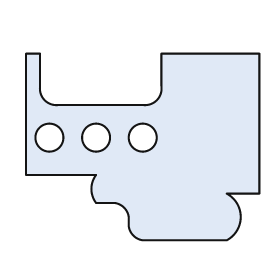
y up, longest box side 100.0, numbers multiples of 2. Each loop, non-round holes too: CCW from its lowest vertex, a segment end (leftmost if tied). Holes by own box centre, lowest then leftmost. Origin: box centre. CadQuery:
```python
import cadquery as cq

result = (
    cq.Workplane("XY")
    .moveTo(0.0, -40.0)
    .lineTo(36.0, -40.0)
    .threePointArc((42.0, -30.0), (36.0, -20.0))
    .lineTo(50.0, -20.0)
    .lineTo(50.0, 40.0)
    .lineTo(8.0, 40.0)
    .lineTo(8.0, 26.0)
    .threePointArc((6.0, 20.0), (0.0, 18.0))
    .lineTo(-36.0, 18.0)
    .threePointArc((-42.0, 20.0), (-44.0, 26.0))
    .lineTo(-44.0, 40.0)
    .lineTo(-50.0, 40.0)
    .lineTo(-50.0, -12.0)
    .lineTo(-20.0, -12.0)
    .threePointArc((-22.0, -18.0), (-20.0, -24.0))
    .lineTo(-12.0, -24.0)
    .threePointArc((-8.0, -26.0), (-6.0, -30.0))
    .lineTo(-6.0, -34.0)
    .threePointArc((-4.0, -38.0), (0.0, -40.0))
    .close()
    .moveTo(-40.0, 4.0)
    .circle(6.0)
    .moveTo(-20.0, 4.0)
    .circle(6.0)
    .moveTo(0.0, 4.0)
    .circle(6.0)
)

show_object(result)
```